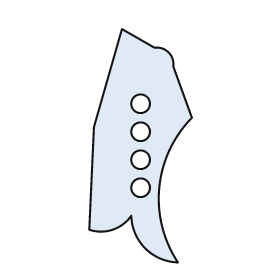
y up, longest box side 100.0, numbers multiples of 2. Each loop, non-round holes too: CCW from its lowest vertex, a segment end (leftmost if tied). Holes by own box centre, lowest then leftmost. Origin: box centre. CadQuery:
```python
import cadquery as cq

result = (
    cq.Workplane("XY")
    .moveTo(16.0, -50.0)
    .threePointArc((8.0, -18.0), (22.0, 12.0))
    .lineTo(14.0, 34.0)
    .threePointArc((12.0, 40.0), (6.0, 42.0))
    .lineTo(-8.0, 50.0)
    .lineTo(-20.0, 8.0)
    .lineTo(-22.0, -36.0)
    .threePointArc((-12.0, -36.0), (-4.0, -30.0))
    .threePointArc((2.0, -44.0), (16.0, -50.0))
    .close()
    .moveTo(0.0, -18.0)
    .circle(4.0)
    .moveTo(0.0, -6.0)
    .circle(4.0)
    .moveTo(0.0, 6.0)
    .circle(4.0)
    .moveTo(0.0, 18.0)
    .circle(4.0)
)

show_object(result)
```